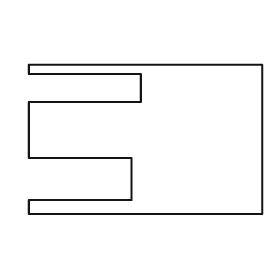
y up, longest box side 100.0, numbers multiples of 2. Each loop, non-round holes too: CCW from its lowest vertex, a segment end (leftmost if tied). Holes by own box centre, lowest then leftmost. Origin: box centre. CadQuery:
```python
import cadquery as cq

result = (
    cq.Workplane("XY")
    .moveTo(-50.0, -32.0)
    .lineTo(50.0, -32.0)
    .lineTo(50.0, 32.0)
    .lineTo(-50.0, 32.0)
    .lineTo(-50.0, 28.0)
    .lineTo(-2.0, 28.0)
    .lineTo(-2.0, 16.0)
    .lineTo(-50.0, 16.0)
    .lineTo(-50.0, -8.0)
    .lineTo(-6.0, -8.0)
    .lineTo(-6.0, -26.0)
    .lineTo(-50.0, -26.0)
    .close()
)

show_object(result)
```